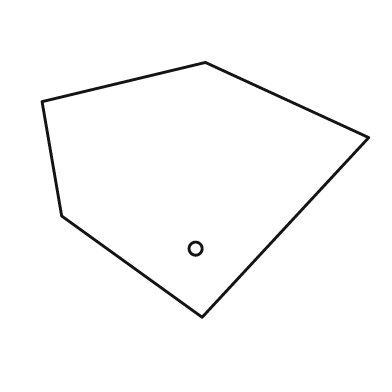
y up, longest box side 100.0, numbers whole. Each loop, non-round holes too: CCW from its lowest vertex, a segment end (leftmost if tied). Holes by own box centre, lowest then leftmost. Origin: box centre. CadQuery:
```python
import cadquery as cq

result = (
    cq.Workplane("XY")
    .moveTo(-1.0, -39.0)
    .lineTo(50.0, 16.0)
    .lineTo(0.0, 39.0)
    .lineTo(-50.0, 27.0)
    .lineTo(-44.0, -8.0)
    .close()
    .moveTo(-3.0, -18.0)
    .circle(2.0)
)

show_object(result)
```